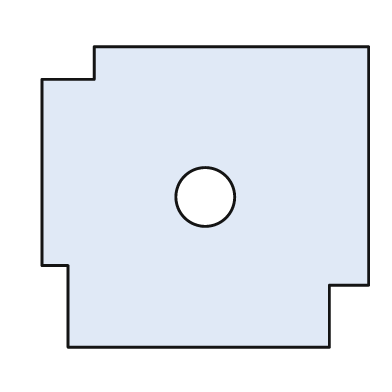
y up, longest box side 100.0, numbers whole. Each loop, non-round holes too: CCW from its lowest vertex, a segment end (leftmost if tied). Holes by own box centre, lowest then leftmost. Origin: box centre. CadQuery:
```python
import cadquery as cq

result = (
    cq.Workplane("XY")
    .moveTo(-42.0, -46.0)
    .lineTo(38.0, -46.0)
    .lineTo(38.0, -27.0)
    .lineTo(50.0, -27.0)
    .lineTo(50.0, 46.0)
    .lineTo(-34.0, 46.0)
    .lineTo(-34.0, 36.0)
    .lineTo(-50.0, 36.0)
    .lineTo(-50.0, -21.0)
    .lineTo(-42.0, -21.0)
    .close()
    .moveTo(0.0, 0.0)
    .circle(9.0)
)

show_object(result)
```